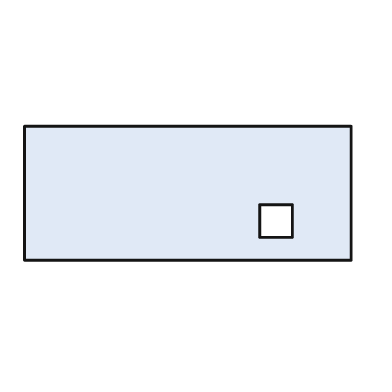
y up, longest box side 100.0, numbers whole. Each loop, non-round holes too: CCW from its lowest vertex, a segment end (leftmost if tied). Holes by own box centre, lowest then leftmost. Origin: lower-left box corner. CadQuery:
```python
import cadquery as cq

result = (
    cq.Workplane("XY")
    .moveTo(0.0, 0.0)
    .lineTo(100.0, 0.0)
    .lineTo(100.0, 41.0)
    .lineTo(0.0, 41.0)
    .close()
    .moveTo(72.0, 7.0)
    .lineTo(82.0, 7.0)
    .lineTo(82.0, 17.0)
    .lineTo(72.0, 17.0)
    .close()
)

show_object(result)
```